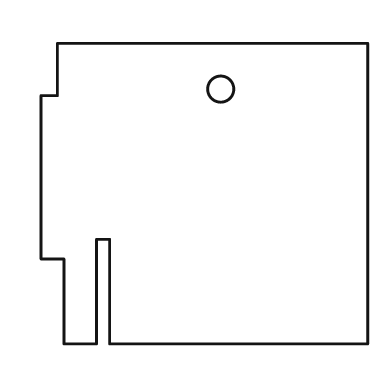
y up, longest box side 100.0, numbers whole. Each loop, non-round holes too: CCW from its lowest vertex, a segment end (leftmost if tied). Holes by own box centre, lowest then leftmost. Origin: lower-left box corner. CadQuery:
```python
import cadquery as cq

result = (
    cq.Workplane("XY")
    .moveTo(7.0, 0.0)
    .lineTo(17.0, 0.0)
    .lineTo(17.0, 32.0)
    .lineTo(21.0, 32.0)
    .lineTo(21.0, 0.0)
    .lineTo(100.0, 0.0)
    .lineTo(100.0, 92.0)
    .lineTo(5.0, 92.0)
    .lineTo(5.0, 76.0)
    .lineTo(0.0, 76.0)
    .lineTo(0.0, 26.0)
    .lineTo(7.0, 26.0)
    .close()
    .moveTo(55.0, 78.0)
    .circle(4.0)
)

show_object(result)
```